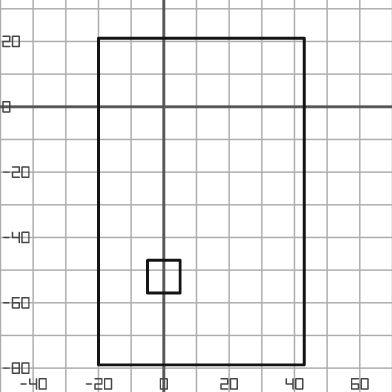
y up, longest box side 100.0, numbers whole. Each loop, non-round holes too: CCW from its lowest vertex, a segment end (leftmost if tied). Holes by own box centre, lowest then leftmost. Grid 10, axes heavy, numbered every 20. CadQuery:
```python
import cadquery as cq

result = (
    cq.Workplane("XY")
    .moveTo(-20.0, -79.0)
    .lineTo(43.0, -79.0)
    .lineTo(43.0, 21.0)
    .lineTo(-20.0, 21.0)
    .close()
    .moveTo(-5.0, -57.0)
    .lineTo(5.0, -57.0)
    .lineTo(5.0, -47.0)
    .lineTo(-5.0, -47.0)
    .close()
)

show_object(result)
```